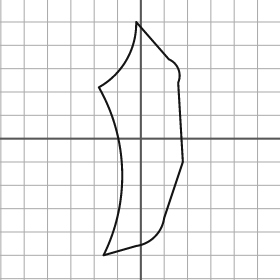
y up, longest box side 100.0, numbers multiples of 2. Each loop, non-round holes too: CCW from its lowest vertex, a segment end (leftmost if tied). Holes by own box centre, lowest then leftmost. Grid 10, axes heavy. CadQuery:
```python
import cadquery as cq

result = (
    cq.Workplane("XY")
    .moveTo(-16.0, -50.0)
    .lineTo(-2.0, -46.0)
    .threePointArc((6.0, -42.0), (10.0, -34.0))
    .lineTo(18.0, -10.0)
    .lineTo(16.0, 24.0)
    .threePointArc((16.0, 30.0), (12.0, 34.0))
    .lineTo(-2.0, 50.0)
    .threePointArc((-6.0, 34.0), (-18.0, 22.0))
    .threePointArc((-8.0, -14.0), (-16.0, -50.0))
    .close()
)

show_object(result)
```